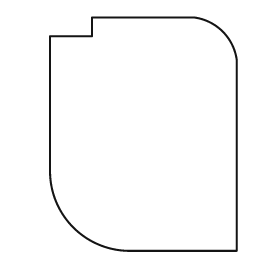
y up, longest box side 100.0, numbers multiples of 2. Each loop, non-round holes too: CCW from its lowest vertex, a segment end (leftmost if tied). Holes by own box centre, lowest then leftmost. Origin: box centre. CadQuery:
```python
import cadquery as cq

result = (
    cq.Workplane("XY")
    .moveTo(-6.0, -50.0)
    .lineTo(40.0, -50.0)
    .lineTo(40.0, 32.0)
    .threePointArc((34.0, 44.0), (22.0, 50.0))
    .lineTo(-22.0, 50.0)
    .lineTo(-22.0, 42.0)
    .lineTo(-40.0, 42.0)
    .lineTo(-40.0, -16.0)
    .threePointArc((-30.0, -40.0), (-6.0, -50.0))
    .close()
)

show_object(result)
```